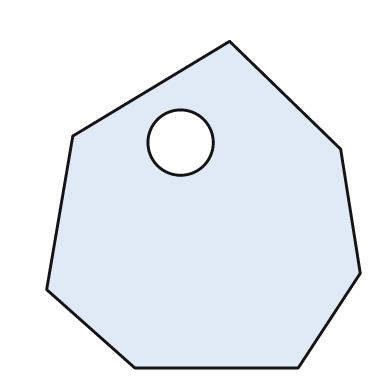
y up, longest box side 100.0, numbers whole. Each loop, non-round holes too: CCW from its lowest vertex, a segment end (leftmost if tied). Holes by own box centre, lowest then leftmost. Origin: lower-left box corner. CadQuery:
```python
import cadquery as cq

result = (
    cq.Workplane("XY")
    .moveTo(27.0, 0.0)
    .lineTo(77.0, 0.0)
    .lineTo(96.0, 29.0)
    .lineTo(90.0, 67.0)
    .lineTo(56.0, 100.0)
    .lineTo(8.0, 71.0)
    .lineTo(0.0, 24.0)
    .close()
    .moveTo(41.0, 69.0)
    .circle(10.0)
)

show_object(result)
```